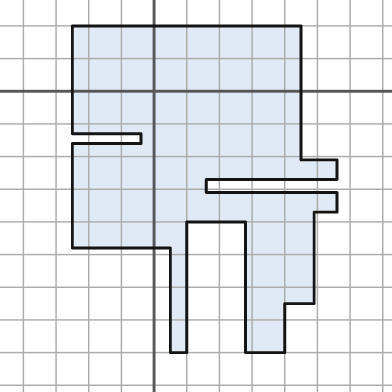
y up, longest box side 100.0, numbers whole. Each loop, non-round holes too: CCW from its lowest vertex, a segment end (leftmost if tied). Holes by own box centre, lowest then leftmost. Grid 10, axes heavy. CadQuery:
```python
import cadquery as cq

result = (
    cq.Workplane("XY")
    .moveTo(5.0, -80.0)
    .lineTo(10.0, -80.0)
    .lineTo(10.0, -40.0)
    .lineTo(28.0, -40.0)
    .lineTo(28.0, -80.0)
    .lineTo(40.0, -80.0)
    .lineTo(40.0, -65.0)
    .lineTo(49.0, -65.0)
    .lineTo(49.0, -37.0)
    .lineTo(56.0, -37.0)
    .lineTo(56.0, -31.0)
    .lineTo(16.0, -31.0)
    .lineTo(16.0, -27.0)
    .lineTo(56.0, -27.0)
    .lineTo(56.0, -21.0)
    .lineTo(45.0, -21.0)
    .lineTo(45.0, 20.0)
    .lineTo(-25.0, 20.0)
    .lineTo(-25.0, -13.0)
    .lineTo(-4.0, -13.0)
    .lineTo(-4.0, -16.0)
    .lineTo(-25.0, -16.0)
    .lineTo(-25.0, -48.0)
    .lineTo(5.0, -48.0)
    .close()
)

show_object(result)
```